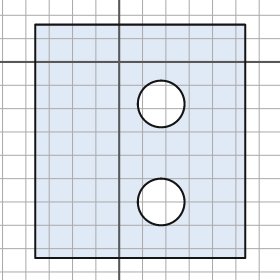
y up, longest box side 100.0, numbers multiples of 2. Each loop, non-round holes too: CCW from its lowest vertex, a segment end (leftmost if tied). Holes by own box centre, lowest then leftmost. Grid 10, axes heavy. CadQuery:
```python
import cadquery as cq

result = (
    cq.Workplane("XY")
    .moveTo(-36.0, -84.0)
    .lineTo(54.0, -84.0)
    .lineTo(54.0, 16.0)
    .lineTo(-36.0, 16.0)
    .close()
    .moveTo(18.0, -60.0)
    .circle(10.0)
    .moveTo(18.0, -18.0)
    .circle(10.0)
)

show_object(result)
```